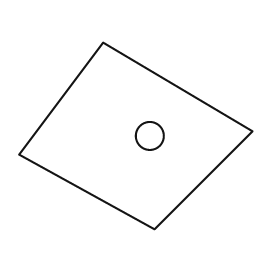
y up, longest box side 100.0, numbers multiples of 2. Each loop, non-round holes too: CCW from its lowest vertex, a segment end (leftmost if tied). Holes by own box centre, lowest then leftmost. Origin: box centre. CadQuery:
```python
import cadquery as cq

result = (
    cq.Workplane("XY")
    .moveTo(8.0, -40.0)
    .lineTo(50.0, 2.0)
    .lineTo(-14.0, 40.0)
    .lineTo(-50.0, -8.0)
    .close()
    .moveTo(6.0, 0.0)
    .circle(6.0)
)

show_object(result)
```